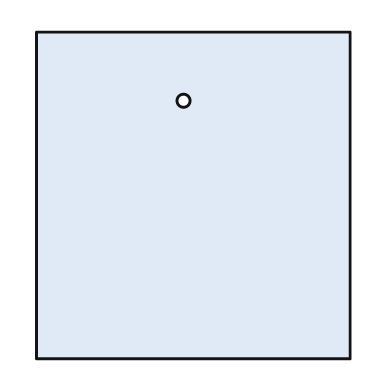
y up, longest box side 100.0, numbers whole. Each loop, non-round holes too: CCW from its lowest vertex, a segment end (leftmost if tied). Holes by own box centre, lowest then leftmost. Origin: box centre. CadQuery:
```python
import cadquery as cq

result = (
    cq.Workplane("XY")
    .moveTo(-48.0, -50.0)
    .lineTo(48.0, -50.0)
    .lineTo(48.0, 50.0)
    .lineTo(-48.0, 50.0)
    .close()
    .moveTo(-3.0, 29.0)
    .circle(2.0)
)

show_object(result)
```